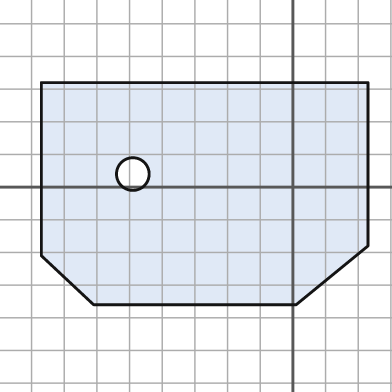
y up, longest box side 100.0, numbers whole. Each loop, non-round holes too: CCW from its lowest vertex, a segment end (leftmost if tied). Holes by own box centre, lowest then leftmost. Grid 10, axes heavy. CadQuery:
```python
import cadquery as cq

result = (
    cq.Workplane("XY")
    .moveTo(-61.0, -36.0)
    .lineTo(1.0, -36.0)
    .lineTo(23.0, -18.0)
    .lineTo(23.0, 32.0)
    .lineTo(-77.0, 32.0)
    .lineTo(-77.0, -21.0)
    .close()
    .moveTo(-49.0, 4.0)
    .circle(5.0)
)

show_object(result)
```